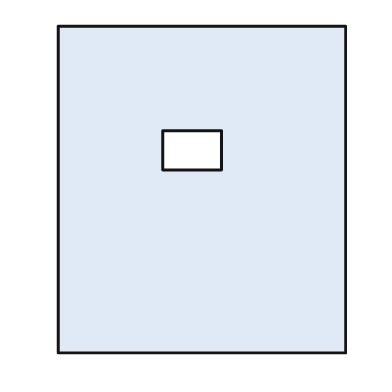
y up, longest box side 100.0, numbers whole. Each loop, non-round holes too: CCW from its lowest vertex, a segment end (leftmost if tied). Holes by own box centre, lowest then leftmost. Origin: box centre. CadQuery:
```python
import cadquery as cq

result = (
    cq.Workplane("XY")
    .moveTo(-44.0, -50.0)
    .lineTo(44.0, -50.0)
    .lineTo(44.0, 50.0)
    .lineTo(-44.0, 50.0)
    .close()
    .moveTo(-12.0, 6.0)
    .lineTo(6.0, 6.0)
    .lineTo(6.0, 18.0)
    .lineTo(-12.0, 18.0)
    .close()
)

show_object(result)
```